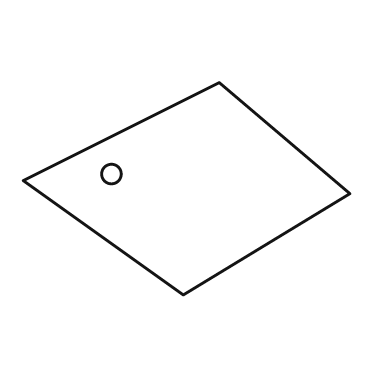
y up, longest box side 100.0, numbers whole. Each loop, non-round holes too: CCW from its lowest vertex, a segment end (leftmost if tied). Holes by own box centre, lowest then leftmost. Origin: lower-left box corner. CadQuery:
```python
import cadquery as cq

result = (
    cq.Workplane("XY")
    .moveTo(49.0, 0.0)
    .lineTo(100.0, 31.0)
    .lineTo(60.0, 65.0)
    .lineTo(0.0, 35.0)
    .close()
    .moveTo(27.0, 37.0)
    .circle(3.0)
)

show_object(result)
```